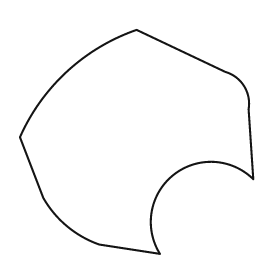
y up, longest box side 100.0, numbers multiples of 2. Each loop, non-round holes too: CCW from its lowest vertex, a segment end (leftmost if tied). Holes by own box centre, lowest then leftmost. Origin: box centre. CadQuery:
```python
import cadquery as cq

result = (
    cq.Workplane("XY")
    .moveTo(10.0, -48.0)
    .threePointArc((16.0, -14.0), (50.0, -16.0))
    .lineTo(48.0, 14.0)
    .threePointArc((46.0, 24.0), (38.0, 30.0))
    .lineTo(0.0, 48.0)
    .threePointArc((-30.0, 30.0), (-50.0, 2.0))
    .lineTo(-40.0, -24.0)
    .threePointArc((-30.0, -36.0), (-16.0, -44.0))
    .close()
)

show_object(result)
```